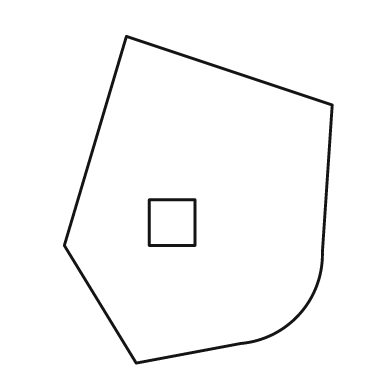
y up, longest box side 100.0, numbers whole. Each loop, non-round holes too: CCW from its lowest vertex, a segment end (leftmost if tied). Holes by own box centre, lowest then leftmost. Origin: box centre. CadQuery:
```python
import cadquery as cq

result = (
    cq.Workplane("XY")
    .moveTo(-19.0, -50.0)
    .lineTo(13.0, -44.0)
    .threePointArc((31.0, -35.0), (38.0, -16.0))
    .lineTo(41.0, 29.0)
    .lineTo(-22.0, 50.0)
    .lineTo(-41.0, -14.0)
    .close()
    .moveTo(-15.0, -14.0)
    .lineTo(-1.0, -14.0)
    .lineTo(-1.0, 0.0)
    .lineTo(-15.0, 0.0)
    .close()
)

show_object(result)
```